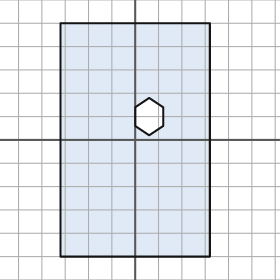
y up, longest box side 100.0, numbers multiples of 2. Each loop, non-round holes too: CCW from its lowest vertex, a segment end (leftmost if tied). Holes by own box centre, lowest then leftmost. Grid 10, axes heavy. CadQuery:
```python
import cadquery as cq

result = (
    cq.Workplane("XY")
    .moveTo(-32.0, -50.0)
    .lineTo(32.0, -50.0)
    .lineTo(32.0, 50.0)
    .lineTo(-32.0, 50.0)
    .close()
    .moveTo(6.0, 2.0)
    .lineTo(12.0, 6.0)
    .lineTo(12.0, 14.0)
    .lineTo(6.0, 18.0)
    .lineTo(0.0, 14.0)
    .lineTo(0.0, 6.0)
    .close()
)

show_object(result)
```